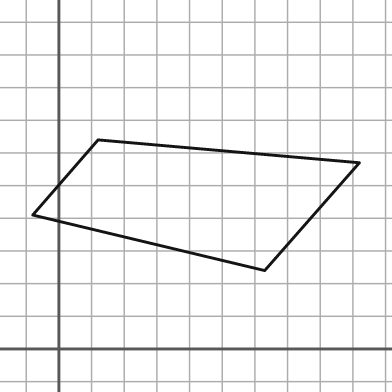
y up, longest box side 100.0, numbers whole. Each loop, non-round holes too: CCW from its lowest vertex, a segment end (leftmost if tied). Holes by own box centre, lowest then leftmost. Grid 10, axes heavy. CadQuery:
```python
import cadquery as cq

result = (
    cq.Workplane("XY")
    .moveTo(63.0, 24.0)
    .lineTo(92.0, 57.0)
    .lineTo(12.0, 64.0)
    .lineTo(-8.0, 41.0)
    .close()
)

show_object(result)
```